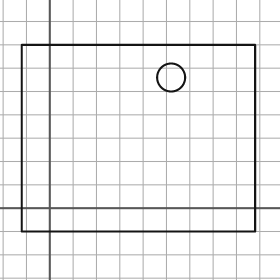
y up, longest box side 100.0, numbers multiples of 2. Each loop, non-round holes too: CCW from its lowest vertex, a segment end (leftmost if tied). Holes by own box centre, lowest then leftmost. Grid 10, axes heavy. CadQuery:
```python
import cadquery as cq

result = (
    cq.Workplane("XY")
    .moveTo(-12.0, -10.0)
    .lineTo(88.0, -10.0)
    .lineTo(88.0, 70.0)
    .lineTo(-12.0, 70.0)
    .close()
    .moveTo(52.0, 56.0)
    .circle(6.0)
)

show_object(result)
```